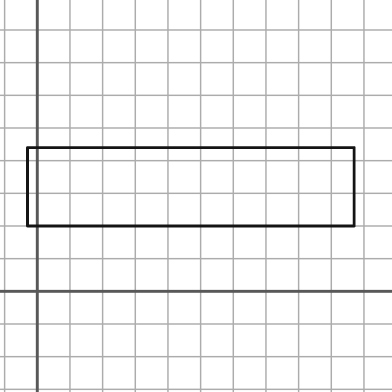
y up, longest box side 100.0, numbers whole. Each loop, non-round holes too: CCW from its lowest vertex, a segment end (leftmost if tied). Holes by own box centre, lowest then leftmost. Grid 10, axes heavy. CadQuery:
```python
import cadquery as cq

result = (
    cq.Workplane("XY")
    .moveTo(-3.0, 20.0)
    .lineTo(97.0, 20.0)
    .lineTo(97.0, 44.0)
    .lineTo(-3.0, 44.0)
    .close()
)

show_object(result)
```